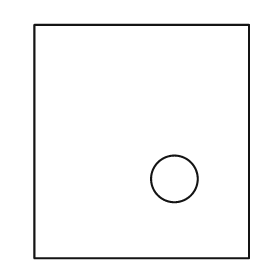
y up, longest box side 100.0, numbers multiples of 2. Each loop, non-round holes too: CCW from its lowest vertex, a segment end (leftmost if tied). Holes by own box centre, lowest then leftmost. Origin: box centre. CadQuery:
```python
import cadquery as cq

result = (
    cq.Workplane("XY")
    .moveTo(-46.0, -50.0)
    .lineTo(46.0, -50.0)
    .lineTo(46.0, 50.0)
    .lineTo(-46.0, 50.0)
    .close()
    .moveTo(14.0, -16.0)
    .circle(10.0)
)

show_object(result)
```